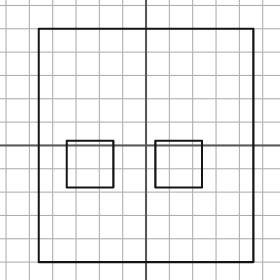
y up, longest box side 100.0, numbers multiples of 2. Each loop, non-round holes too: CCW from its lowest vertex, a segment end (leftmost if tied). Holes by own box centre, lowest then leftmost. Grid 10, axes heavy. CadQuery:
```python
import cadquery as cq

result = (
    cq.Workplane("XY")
    .moveTo(-46.0, -50.0)
    .lineTo(46.0, -50.0)
    .lineTo(46.0, 50.0)
    .lineTo(-46.0, 50.0)
    .close()
    .moveTo(-34.0, -18.0)
    .lineTo(-14.0, -18.0)
    .lineTo(-14.0, 2.0)
    .lineTo(-34.0, 2.0)
    .close()
    .moveTo(4.0, -18.0)
    .lineTo(24.0, -18.0)
    .lineTo(24.0, 2.0)
    .lineTo(4.0, 2.0)
    .close()
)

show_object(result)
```